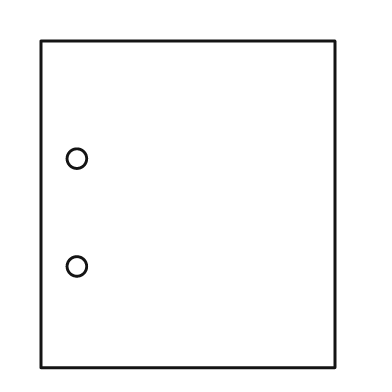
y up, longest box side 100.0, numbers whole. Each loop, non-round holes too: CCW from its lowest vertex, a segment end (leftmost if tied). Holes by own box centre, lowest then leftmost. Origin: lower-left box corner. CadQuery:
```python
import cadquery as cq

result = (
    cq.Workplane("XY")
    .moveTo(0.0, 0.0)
    .lineTo(90.0, 0.0)
    .lineTo(90.0, 100.0)
    .lineTo(0.0, 100.0)
    .close()
    .moveTo(11.0, 31.0)
    .circle(3.0)
    .moveTo(11.0, 64.0)
    .circle(3.0)
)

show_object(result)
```